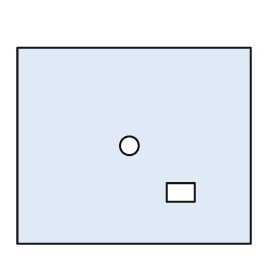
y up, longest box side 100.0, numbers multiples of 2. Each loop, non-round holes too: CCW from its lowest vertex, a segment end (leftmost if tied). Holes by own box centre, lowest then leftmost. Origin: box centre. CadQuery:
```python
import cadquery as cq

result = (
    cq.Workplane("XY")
    .moveTo(-50.0, -42.0)
    .lineTo(50.0, -42.0)
    .lineTo(50.0, 42.0)
    .lineTo(-50.0, 42.0)
    .close()
    .moveTo(14.0, -24.0)
    .lineTo(26.0, -24.0)
    .lineTo(26.0, -16.0)
    .lineTo(14.0, -16.0)
    .close()
    .moveTo(-2.0, 0.0)
    .circle(4.0)
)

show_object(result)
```